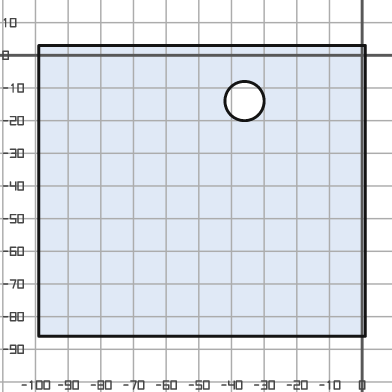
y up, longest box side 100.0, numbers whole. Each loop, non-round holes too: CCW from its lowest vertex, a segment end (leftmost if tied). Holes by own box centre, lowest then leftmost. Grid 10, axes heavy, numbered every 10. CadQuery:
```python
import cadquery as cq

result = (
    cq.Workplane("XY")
    .moveTo(-99.0, -86.0)
    .lineTo(1.0, -86.0)
    .lineTo(1.0, 3.0)
    .lineTo(-99.0, 3.0)
    .close()
    .moveTo(-36.0, -14.0)
    .circle(6.0)
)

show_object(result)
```